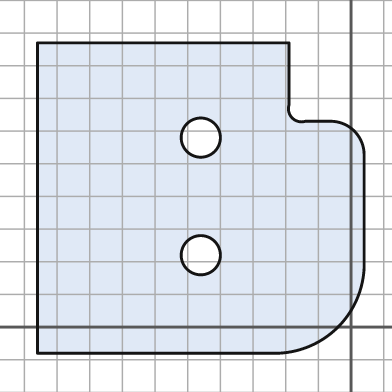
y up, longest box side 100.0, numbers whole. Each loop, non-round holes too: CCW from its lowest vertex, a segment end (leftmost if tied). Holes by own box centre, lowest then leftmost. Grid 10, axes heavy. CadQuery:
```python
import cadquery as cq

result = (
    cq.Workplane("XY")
    .moveTo(-96.0, -8.0)
    .lineTo(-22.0, -8.0)
    .threePointArc((-4.0, 0.0), (4.0, 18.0))
    .lineTo(4.0, 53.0)
    .threePointArc((1.0, 60.0), (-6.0, 63.0))
    .lineTo(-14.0, 63.0)
    .threePointArc((-18.0, 64.0), (-19.0, 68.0))
    .lineTo(-19.0, 87.0)
    .lineTo(-96.0, 87.0)
    .close()
    .moveTo(-46.0, 22.0)
    .circle(6.0)
    .moveTo(-46.0, 58.0)
    .circle(6.0)
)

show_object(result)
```